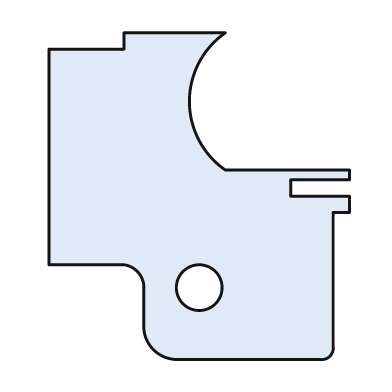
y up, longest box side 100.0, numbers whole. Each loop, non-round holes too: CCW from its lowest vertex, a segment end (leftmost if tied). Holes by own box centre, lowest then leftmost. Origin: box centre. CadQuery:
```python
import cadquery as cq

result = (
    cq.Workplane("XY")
    .moveTo(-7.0, -50.0)
    .lineTo(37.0, -50.0)
    .threePointArc((40.0, -49.0), (41.0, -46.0))
    .lineTo(41.0, -5.0)
    .lineTo(46.0, -5.0)
    .lineTo(46.0, 0.0)
    .lineTo(28.0, 0.0)
    .lineTo(28.0, 5.0)
    .lineTo(46.0, 5.0)
    .lineTo(46.0, 8.0)
    .lineTo(8.0, 8.0)
    .threePointArc((-3.0, 29.0), (8.0, 50.0))
    .lineTo(-23.0, 50.0)
    .lineTo(-23.0, 45.0)
    .lineTo(-46.0, 45.0)
    .lineTo(-46.0, -21.0)
    .lineTo(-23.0, -21.0)
    .threePointArc((-19.0, -23.0), (-17.0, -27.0))
    .lineTo(-17.0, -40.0)
    .threePointArc((-14.0, -47.0), (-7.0, -50.0))
    .close()
    .moveTo(0.0, -28.0)
    .circle(7.0)
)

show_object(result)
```